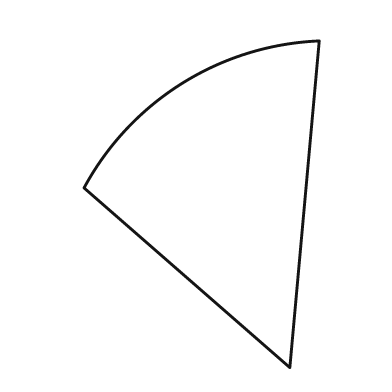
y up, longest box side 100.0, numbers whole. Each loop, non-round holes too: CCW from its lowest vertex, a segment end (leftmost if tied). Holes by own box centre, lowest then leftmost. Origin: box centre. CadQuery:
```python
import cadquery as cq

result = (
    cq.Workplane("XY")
    .moveTo(27.0, -50.0)
    .lineTo(36.0, 50.0)
    .threePointArc((-6.0, 37.0), (-36.0, 5.0))
    .close()
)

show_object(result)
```